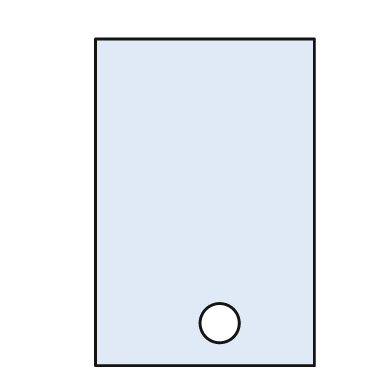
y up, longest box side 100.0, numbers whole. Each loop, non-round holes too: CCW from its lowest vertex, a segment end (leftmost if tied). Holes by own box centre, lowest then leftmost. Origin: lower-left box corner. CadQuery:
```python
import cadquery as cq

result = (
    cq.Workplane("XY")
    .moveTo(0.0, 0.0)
    .lineTo(67.0, 0.0)
    .lineTo(67.0, 100.0)
    .lineTo(0.0, 100.0)
    .close()
    .moveTo(38.0, 13.0)
    .circle(6.0)
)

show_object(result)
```